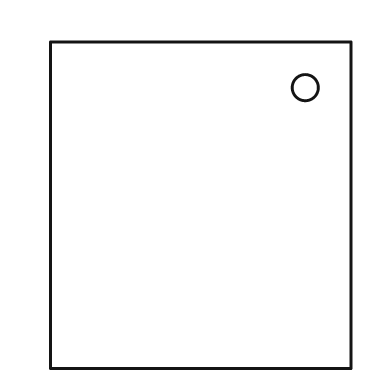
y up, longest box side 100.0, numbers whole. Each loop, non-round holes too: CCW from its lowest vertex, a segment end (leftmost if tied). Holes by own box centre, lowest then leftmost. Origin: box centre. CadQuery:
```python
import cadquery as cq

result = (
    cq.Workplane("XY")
    .moveTo(-46.0, -50.0)
    .lineTo(46.0, -50.0)
    .lineTo(46.0, 50.0)
    .lineTo(-46.0, 50.0)
    .close()
    .moveTo(32.0, 36.0)
    .circle(4.0)
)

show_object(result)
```